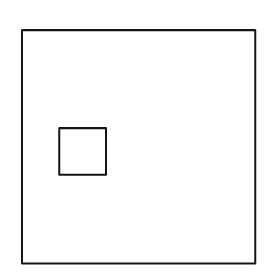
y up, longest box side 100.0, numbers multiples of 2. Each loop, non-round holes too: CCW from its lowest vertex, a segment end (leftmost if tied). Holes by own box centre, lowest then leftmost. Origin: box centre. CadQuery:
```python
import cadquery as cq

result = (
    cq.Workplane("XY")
    .moveTo(-50.0, -50.0)
    .lineTo(50.0, -50.0)
    .lineTo(50.0, 50.0)
    .lineTo(-50.0, 50.0)
    .close()
    .moveTo(-34.0, -12.0)
    .lineTo(-14.0, -12.0)
    .lineTo(-14.0, 8.0)
    .lineTo(-34.0, 8.0)
    .close()
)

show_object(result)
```